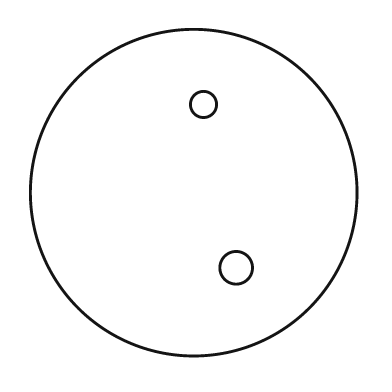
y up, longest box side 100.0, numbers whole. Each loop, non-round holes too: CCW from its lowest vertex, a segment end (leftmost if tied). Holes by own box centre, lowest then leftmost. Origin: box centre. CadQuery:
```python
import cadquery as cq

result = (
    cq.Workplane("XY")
    .moveTo(0.0, 0.0)
    .circle(50.0)
    .moveTo(13.0, -23.0)
    .circle(5.0)
    .moveTo(3.0, 27.0)
    .circle(4.0)
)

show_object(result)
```